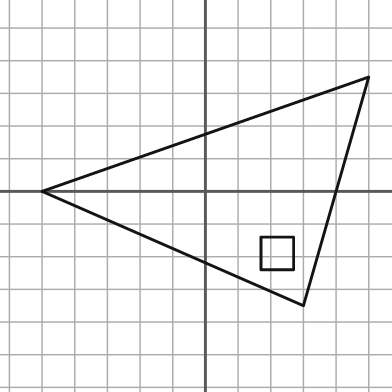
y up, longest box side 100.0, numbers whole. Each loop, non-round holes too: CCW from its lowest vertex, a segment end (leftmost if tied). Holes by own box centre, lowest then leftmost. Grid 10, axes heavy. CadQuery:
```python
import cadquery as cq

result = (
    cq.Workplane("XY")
    .moveTo(30.0, -35.0)
    .lineTo(50.0, 35.0)
    .lineTo(-50.0, 0.0)
    .close()
    .moveTo(17.0, -24.0)
    .lineTo(27.0, -24.0)
    .lineTo(27.0, -14.0)
    .lineTo(17.0, -14.0)
    .close()
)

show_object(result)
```